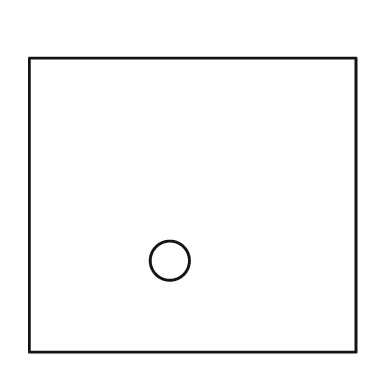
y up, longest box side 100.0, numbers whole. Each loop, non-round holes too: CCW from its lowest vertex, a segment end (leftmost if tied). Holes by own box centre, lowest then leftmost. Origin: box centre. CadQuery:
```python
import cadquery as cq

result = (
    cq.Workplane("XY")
    .moveTo(-50.0, -45.0)
    .lineTo(50.0, -45.0)
    .lineTo(50.0, 45.0)
    .lineTo(-50.0, 45.0)
    .close()
    .moveTo(-7.0, -17.0)
    .circle(6.0)
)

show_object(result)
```